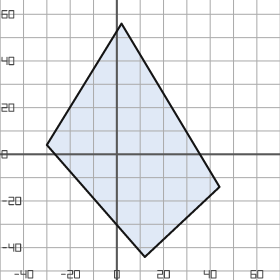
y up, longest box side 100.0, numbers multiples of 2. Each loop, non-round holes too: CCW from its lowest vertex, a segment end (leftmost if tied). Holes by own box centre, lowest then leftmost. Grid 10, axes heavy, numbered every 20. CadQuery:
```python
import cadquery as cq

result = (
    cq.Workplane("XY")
    .moveTo(12.0, -44.0)
    .lineTo(44.0, -14.0)
    .lineTo(2.0, 56.0)
    .lineTo(-30.0, 4.0)
    .close()
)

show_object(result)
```